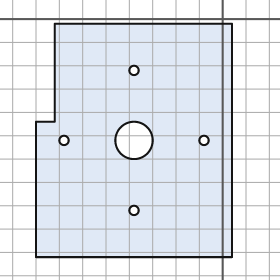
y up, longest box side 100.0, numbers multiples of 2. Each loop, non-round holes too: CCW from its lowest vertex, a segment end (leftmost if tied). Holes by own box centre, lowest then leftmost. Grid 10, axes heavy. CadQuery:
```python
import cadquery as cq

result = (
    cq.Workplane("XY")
    .moveTo(-80.0, -102.0)
    .lineTo(4.0, -102.0)
    .lineTo(4.0, -2.0)
    .lineTo(-72.0, -2.0)
    .lineTo(-72.0, -44.0)
    .lineTo(-80.0, -44.0)
    .close()
    .moveTo(-38.0, -82.0)
    .circle(2.0)
    .moveTo(-68.0, -52.0)
    .circle(2.0)
    .moveTo(-38.0, -52.0)
    .circle(8.0)
    .moveTo(-8.0, -52.0)
    .circle(2.0)
    .moveTo(-38.0, -22.0)
    .circle(2.0)
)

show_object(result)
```